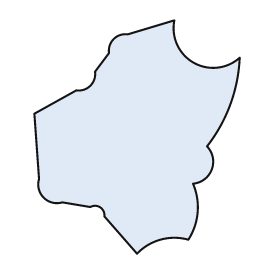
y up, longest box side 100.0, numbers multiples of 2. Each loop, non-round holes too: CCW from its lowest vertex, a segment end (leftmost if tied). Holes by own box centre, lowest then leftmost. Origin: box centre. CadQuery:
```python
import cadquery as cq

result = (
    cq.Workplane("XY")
    .moveTo(0.0, -50.0)
    .threePointArc((10.0, -44.0), (22.0, -44.0))
    .threePointArc((26.0, -32.0), (24.0, -20.0))
    .threePointArc((32.0, -14.0), (30.0, -4.0))
    .threePointArc((40.0, 14.0), (44.0, 34.0))
    .threePointArc((24.0, 32.0), (16.0, 50.0))
    .lineTo(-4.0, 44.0)
    .threePointArc((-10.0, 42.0), (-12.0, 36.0))
    .lineTo(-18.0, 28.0)
    .threePointArc((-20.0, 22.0), (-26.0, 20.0))
    .lineTo(-44.0, 10.0)
    .lineTo(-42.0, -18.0)
    .threePointArc((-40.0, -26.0), (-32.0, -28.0))
    .lineTo(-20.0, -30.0)
    .threePointArc((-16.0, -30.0), (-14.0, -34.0))
    .close()
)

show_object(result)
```